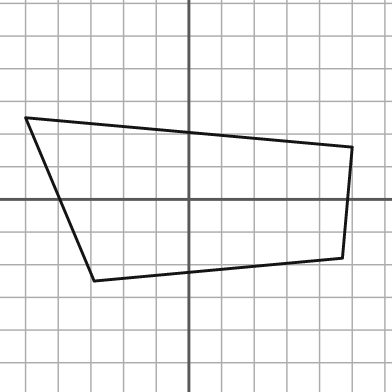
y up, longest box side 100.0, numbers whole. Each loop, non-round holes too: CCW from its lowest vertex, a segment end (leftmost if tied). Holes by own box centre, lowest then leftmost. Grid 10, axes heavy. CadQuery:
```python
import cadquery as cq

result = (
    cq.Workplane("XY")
    .moveTo(-29.0, -25.0)
    .lineTo(47.0, -18.0)
    .lineTo(50.0, 16.0)
    .lineTo(-50.0, 25.0)
    .close()
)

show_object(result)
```